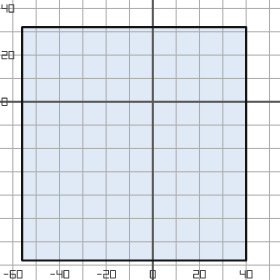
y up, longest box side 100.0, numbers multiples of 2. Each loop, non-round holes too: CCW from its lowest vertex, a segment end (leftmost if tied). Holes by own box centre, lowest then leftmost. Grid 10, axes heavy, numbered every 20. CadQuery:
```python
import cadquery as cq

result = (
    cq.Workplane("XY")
    .moveTo(-56.0, -68.0)
    .lineTo(40.0, -68.0)
    .lineTo(40.0, 32.0)
    .lineTo(-56.0, 32.0)
    .close()
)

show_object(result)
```